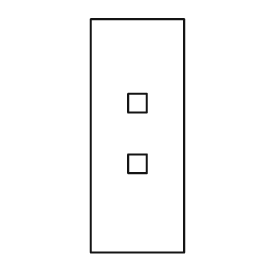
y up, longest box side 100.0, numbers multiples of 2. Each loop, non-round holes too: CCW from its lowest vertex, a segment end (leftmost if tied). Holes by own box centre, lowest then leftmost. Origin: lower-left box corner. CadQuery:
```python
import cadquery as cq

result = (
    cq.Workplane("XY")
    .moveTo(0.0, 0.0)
    .lineTo(40.0, 0.0)
    .lineTo(40.0, 100.0)
    .lineTo(0.0, 100.0)
    .close()
    .moveTo(16.0, 34.0)
    .lineTo(24.0, 34.0)
    .lineTo(24.0, 42.0)
    .lineTo(16.0, 42.0)
    .close()
    .moveTo(16.0, 60.0)
    .lineTo(24.0, 60.0)
    .lineTo(24.0, 68.0)
    .lineTo(16.0, 68.0)
    .close()
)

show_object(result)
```